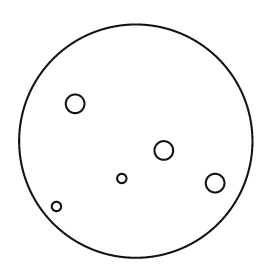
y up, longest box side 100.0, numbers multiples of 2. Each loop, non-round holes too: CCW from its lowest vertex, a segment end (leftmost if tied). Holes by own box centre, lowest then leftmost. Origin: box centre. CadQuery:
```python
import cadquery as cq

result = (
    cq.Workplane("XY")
    .moveTo(0.0, 0.0)
    .circle(50.0)
    .moveTo(-34.0, -28.0)
    .circle(2.0)
    .moveTo(34.0, -18.0)
    .circle(4.0)
    .moveTo(-6.0, -16.0)
    .circle(2.0)
    .moveTo(12.0, -4.0)
    .circle(4.0)
    .moveTo(-26.0, 16.0)
    .circle(4.0)
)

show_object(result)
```